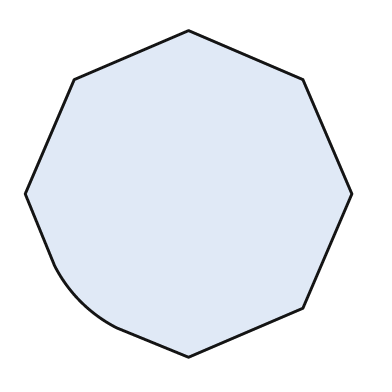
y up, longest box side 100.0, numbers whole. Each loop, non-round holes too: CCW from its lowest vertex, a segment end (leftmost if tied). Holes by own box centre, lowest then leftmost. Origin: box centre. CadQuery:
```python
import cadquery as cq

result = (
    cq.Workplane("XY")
    .moveTo(0.0, -50.0)
    .lineTo(35.0, -35.0)
    .lineTo(50.0, 0.0)
    .lineTo(35.0, 35.0)
    .lineTo(0.0, 50.0)
    .lineTo(-35.0, 35.0)
    .lineTo(-50.0, 0.0)
    .lineTo(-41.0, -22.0)
    .threePointArc((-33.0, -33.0), (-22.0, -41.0))
    .close()
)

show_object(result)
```